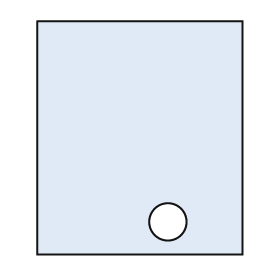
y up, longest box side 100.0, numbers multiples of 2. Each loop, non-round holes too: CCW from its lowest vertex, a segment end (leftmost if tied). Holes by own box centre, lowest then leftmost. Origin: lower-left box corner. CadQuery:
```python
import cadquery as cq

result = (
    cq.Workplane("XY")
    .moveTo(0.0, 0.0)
    .lineTo(88.0, 0.0)
    .lineTo(88.0, 100.0)
    .lineTo(0.0, 100.0)
    .close()
    .moveTo(56.0, 14.0)
    .circle(8.0)
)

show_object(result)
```